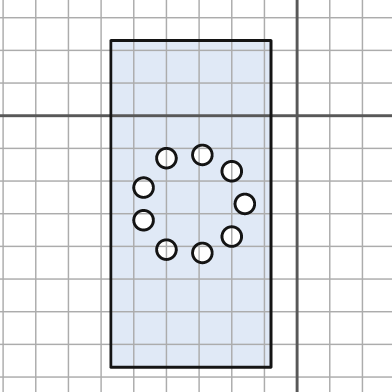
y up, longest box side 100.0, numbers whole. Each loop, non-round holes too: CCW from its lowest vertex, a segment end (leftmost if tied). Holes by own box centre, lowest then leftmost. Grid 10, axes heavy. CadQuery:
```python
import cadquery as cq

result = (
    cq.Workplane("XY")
    .moveTo(-57.0, -77.0)
    .lineTo(-8.0, -77.0)
    .lineTo(-8.0, 23.0)
    .lineTo(-57.0, 23.0)
    .close()
    .moveTo(-29.0, -42.0)
    .circle(3.0)
    .moveTo(-40.0, -41.0)
    .circle(3.0)
    .moveTo(-20.0, -37.0)
    .circle(3.0)
    .moveTo(-47.0, -32.0)
    .circle(3.0)
    .moveTo(-16.0, -27.0)
    .circle(3.0)
    .moveTo(-47.0, -22.0)
    .circle(3.0)
    .moveTo(-20.0, -17.0)
    .circle(3.0)
    .moveTo(-40.0, -13.0)
    .circle(3.0)
    .moveTo(-29.0, -12.0)
    .circle(3.0)
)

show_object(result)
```